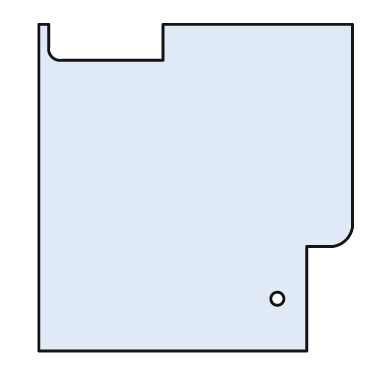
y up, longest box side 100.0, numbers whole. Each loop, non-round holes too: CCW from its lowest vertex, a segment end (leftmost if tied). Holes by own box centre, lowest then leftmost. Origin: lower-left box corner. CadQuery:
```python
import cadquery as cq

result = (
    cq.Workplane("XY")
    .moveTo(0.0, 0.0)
    .lineTo(82.0, 0.0)
    .lineTo(82.0, 32.0)
    .lineTo(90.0, 32.0)
    .threePointArc((94.0, 34.0), (96.0, 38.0))
    .lineTo(96.0, 100.0)
    .lineTo(38.0, 100.0)
    .lineTo(38.0, 89.0)
    .lineTo(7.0, 89.0)
    .threePointArc((4.0, 90.0), (3.0, 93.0))
    .lineTo(3.0, 100.0)
    .lineTo(0.0, 100.0)
    .close()
    .moveTo(73.0, 16.0)
    .circle(2.0)
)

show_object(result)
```